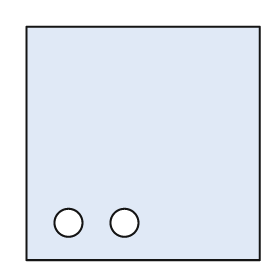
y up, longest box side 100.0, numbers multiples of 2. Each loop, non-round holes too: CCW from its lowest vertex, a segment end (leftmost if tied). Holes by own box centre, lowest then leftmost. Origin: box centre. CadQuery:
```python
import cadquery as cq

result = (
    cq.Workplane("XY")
    .moveTo(-50.0, -50.0)
    .lineTo(50.0, -50.0)
    .lineTo(50.0, 50.0)
    .lineTo(-50.0, 50.0)
    .close()
    .moveTo(-32.0, -34.0)
    .circle(6.0)
    .moveTo(-8.0, -34.0)
    .circle(6.0)
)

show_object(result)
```